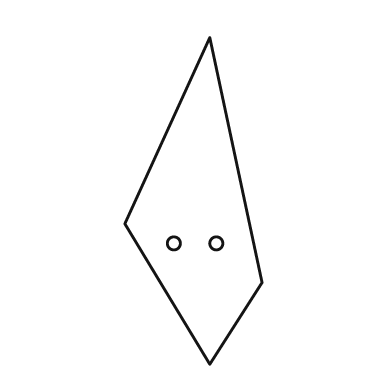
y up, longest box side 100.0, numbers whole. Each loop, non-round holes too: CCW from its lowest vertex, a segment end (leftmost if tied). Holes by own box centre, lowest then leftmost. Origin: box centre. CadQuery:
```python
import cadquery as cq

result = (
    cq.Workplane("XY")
    .moveTo(5.0, -50.0)
    .lineTo(21.0, -25.0)
    .lineTo(5.0, 50.0)
    .lineTo(-21.0, -7.0)
    .close()
    .moveTo(-6.0, -13.0)
    .circle(2.0)
    .moveTo(7.0, -13.0)
    .circle(2.0)
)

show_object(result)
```